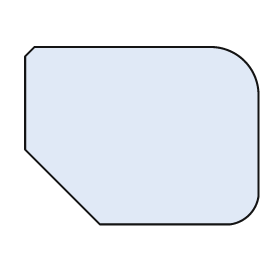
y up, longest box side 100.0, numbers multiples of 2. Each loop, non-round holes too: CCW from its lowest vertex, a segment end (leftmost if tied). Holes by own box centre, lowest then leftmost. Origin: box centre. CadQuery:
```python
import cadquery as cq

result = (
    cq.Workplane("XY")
    .moveTo(-18.0, -38.0)
    .lineTo(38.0, -38.0)
    .threePointArc((46.0, -34.0), (50.0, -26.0))
    .lineTo(50.0, 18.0)
    .threePointArc((44.0, 32.0), (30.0, 38.0))
    .lineTo(-46.0, 38.0)
    .lineTo(-50.0, 34.0)
    .lineTo(-50.0, -6.0)
    .close()
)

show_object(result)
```